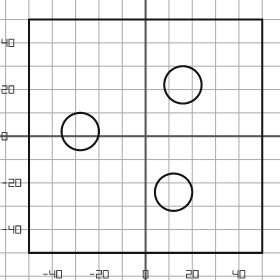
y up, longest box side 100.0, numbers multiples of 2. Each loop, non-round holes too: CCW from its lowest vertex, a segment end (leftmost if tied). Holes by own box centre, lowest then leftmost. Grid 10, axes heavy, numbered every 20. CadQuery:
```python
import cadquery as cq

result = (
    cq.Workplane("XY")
    .moveTo(-50.0, -50.0)
    .lineTo(50.0, -50.0)
    .lineTo(50.0, 50.0)
    .lineTo(-50.0, 50.0)
    .close()
    .moveTo(12.0, -24.0)
    .circle(8.0)
    .moveTo(-28.0, 2.0)
    .circle(8.0)
    .moveTo(16.0, 22.0)
    .circle(8.0)
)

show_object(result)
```